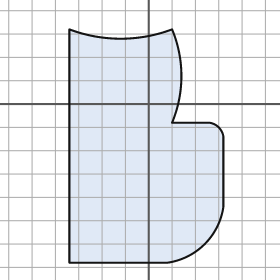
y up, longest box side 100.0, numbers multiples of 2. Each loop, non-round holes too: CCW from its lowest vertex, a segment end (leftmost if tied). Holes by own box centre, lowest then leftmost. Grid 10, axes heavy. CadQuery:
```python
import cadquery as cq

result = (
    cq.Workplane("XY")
    .moveTo(-34.0, -68.0)
    .lineTo(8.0, -68.0)
    .threePointArc((24.0, -60.0), (32.0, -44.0))
    .lineTo(32.0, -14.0)
    .threePointArc((30.0, -10.0), (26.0, -8.0))
    .lineTo(10.0, -8.0)
    .threePointArc((14.0, 12.0), (10.0, 32.0))
    .threePointArc((-12.0, 28.0), (-34.0, 32.0))
    .close()
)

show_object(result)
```